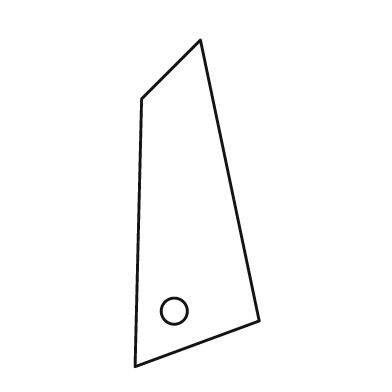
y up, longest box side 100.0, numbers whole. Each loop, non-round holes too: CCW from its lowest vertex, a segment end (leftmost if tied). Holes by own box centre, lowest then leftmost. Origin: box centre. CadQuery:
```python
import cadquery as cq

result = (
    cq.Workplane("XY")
    .moveTo(-19.0, -50.0)
    .lineTo(19.0, -36.0)
    .lineTo(1.0, 50.0)
    .lineTo(-17.0, 32.0)
    .close()
    .moveTo(-7.0, -33.0)
    .circle(4.0)
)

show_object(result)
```